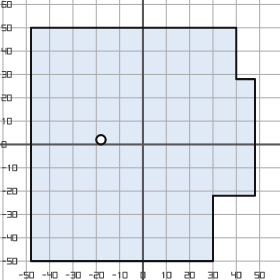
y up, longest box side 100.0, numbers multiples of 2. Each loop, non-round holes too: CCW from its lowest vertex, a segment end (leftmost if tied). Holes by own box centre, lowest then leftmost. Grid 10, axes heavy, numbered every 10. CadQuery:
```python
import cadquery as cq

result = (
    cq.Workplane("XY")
    .moveTo(-48.0, -50.0)
    .lineTo(30.0, -50.0)
    .lineTo(30.0, -22.0)
    .lineTo(48.0, -22.0)
    .lineTo(48.0, 28.0)
    .lineTo(40.0, 28.0)
    .lineTo(40.0, 50.0)
    .lineTo(-48.0, 50.0)
    .close()
    .moveTo(-18.0, 2.0)
    .circle(2.0)
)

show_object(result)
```